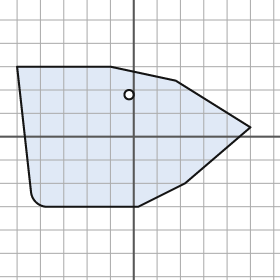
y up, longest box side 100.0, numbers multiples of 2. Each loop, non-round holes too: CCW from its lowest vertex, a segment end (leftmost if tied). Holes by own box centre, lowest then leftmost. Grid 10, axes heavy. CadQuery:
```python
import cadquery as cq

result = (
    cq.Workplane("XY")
    .moveTo(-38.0, -30.0)
    .lineTo(2.0, -30.0)
    .lineTo(22.0, -20.0)
    .lineTo(50.0, 4.0)
    .lineTo(18.0, 24.0)
    .lineTo(-10.0, 30.0)
    .lineTo(-50.0, 30.0)
    .lineTo(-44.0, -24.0)
    .threePointArc((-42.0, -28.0), (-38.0, -30.0))
    .close()
    .moveTo(-2.0, 18.0)
    .circle(2.0)
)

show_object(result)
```